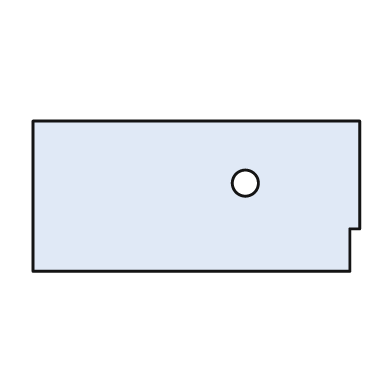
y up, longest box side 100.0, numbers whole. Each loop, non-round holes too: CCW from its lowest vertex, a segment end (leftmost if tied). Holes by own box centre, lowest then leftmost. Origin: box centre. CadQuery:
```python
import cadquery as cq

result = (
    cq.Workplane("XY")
    .moveTo(-50.0, -23.0)
    .lineTo(47.0, -23.0)
    .lineTo(47.0, -10.0)
    .lineTo(50.0, -10.0)
    .lineTo(50.0, 23.0)
    .lineTo(-50.0, 23.0)
    .close()
    .moveTo(15.0, 4.0)
    .circle(4.0)
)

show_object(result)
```